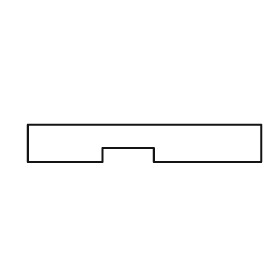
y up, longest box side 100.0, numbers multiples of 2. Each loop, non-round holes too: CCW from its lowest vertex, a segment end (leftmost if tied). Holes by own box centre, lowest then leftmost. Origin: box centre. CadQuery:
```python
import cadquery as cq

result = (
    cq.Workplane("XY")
    .moveTo(-50.0, -8.0)
    .lineTo(-18.0, -8.0)
    .lineTo(-18.0, -2.0)
    .lineTo(4.0, -2.0)
    .lineTo(4.0, -8.0)
    .lineTo(50.0, -8.0)
    .lineTo(50.0, 8.0)
    .lineTo(-50.0, 8.0)
    .close()
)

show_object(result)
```